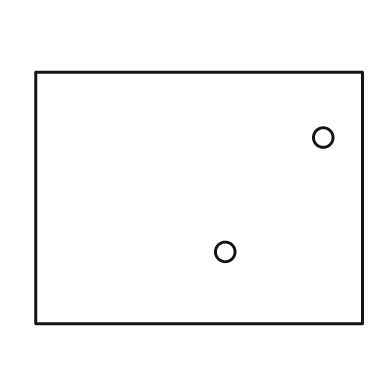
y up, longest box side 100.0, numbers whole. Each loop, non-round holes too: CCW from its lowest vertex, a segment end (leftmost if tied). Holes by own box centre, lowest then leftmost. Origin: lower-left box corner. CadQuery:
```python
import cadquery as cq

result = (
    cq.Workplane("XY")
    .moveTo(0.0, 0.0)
    .lineTo(100.0, 0.0)
    .lineTo(100.0, 77.0)
    .lineTo(0.0, 77.0)
    .close()
    .moveTo(58.0, 22.0)
    .circle(3.0)
    .moveTo(88.0, 57.0)
    .circle(3.0)
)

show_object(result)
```